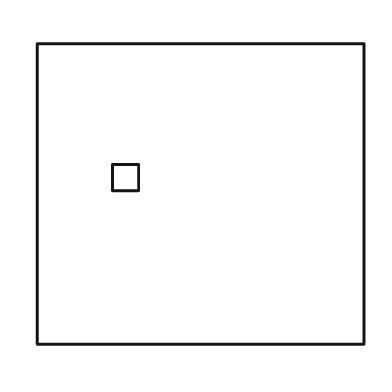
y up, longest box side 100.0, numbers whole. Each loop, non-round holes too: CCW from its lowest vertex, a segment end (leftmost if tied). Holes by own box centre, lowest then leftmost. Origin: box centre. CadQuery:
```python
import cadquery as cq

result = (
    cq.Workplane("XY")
    .moveTo(-50.0, -46.0)
    .lineTo(50.0, -46.0)
    .lineTo(50.0, 46.0)
    .lineTo(-50.0, 46.0)
    .close()
    .moveTo(-27.0, 1.0)
    .lineTo(-19.0, 1.0)
    .lineTo(-19.0, 9.0)
    .lineTo(-27.0, 9.0)
    .close()
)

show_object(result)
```